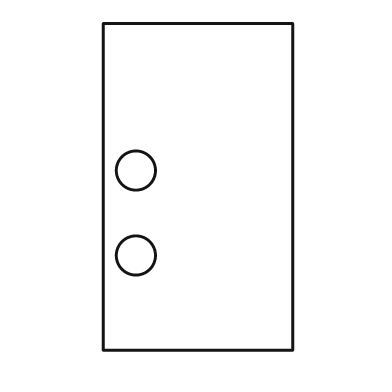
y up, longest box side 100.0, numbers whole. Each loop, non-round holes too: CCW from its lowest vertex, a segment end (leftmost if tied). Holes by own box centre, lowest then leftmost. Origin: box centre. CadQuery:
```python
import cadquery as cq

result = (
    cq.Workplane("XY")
    .moveTo(-29.0, -50.0)
    .lineTo(29.0, -50.0)
    .lineTo(29.0, 50.0)
    .lineTo(-29.0, 50.0)
    .close()
    .moveTo(-19.0, -21.0)
    .circle(6.0)
    .moveTo(-19.0, 5.0)
    .circle(6.0)
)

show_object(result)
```